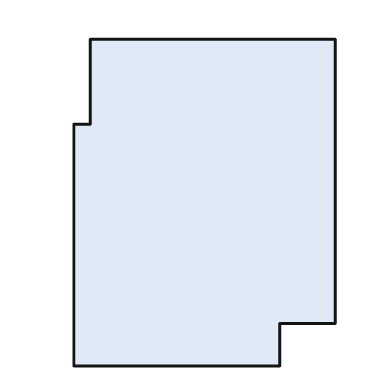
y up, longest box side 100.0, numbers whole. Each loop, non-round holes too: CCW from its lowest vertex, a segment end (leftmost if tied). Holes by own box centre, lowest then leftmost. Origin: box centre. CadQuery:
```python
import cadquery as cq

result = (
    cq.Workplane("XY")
    .moveTo(-40.0, -50.0)
    .lineTo(23.0, -50.0)
    .lineTo(23.0, -37.0)
    .lineTo(40.0, -37.0)
    .lineTo(40.0, 50.0)
    .lineTo(-35.0, 50.0)
    .lineTo(-35.0, 24.0)
    .lineTo(-40.0, 24.0)
    .close()
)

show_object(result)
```